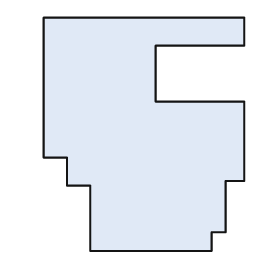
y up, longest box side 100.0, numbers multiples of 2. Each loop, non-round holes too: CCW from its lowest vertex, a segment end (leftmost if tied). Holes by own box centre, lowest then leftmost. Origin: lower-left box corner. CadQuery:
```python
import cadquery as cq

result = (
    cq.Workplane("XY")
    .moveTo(20.0, 0.0)
    .lineTo(72.0, 0.0)
    .lineTo(72.0, 8.0)
    .lineTo(78.0, 8.0)
    .lineTo(78.0, 30.0)
    .lineTo(86.0, 30.0)
    .lineTo(86.0, 64.0)
    .lineTo(48.0, 64.0)
    .lineTo(48.0, 88.0)
    .lineTo(86.0, 88.0)
    .lineTo(86.0, 100.0)
    .lineTo(0.0, 100.0)
    .lineTo(0.0, 40.0)
    .lineTo(10.0, 40.0)
    .lineTo(10.0, 28.0)
    .lineTo(20.0, 28.0)
    .close()
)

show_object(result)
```